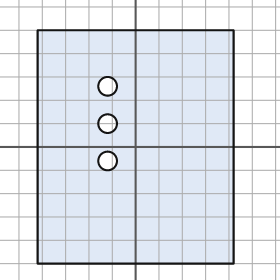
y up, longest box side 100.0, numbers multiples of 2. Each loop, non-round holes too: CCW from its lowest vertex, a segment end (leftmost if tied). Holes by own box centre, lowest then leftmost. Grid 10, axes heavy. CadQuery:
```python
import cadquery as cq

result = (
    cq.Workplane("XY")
    .moveTo(-42.0, -50.0)
    .lineTo(42.0, -50.0)
    .lineTo(42.0, 50.0)
    .lineTo(-42.0, 50.0)
    .close()
    .moveTo(-12.0, -6.0)
    .circle(4.0)
    .moveTo(-12.0, 10.0)
    .circle(4.0)
    .moveTo(-12.0, 26.0)
    .circle(4.0)
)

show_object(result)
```